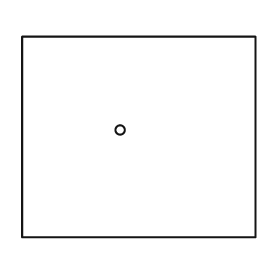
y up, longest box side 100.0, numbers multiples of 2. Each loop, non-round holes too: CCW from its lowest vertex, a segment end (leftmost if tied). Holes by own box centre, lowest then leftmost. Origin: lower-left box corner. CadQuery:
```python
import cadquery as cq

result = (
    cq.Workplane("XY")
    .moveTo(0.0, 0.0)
    .lineTo(100.0, 0.0)
    .lineTo(100.0, 86.0)
    .lineTo(0.0, 86.0)
    .close()
    .moveTo(42.0, 46.0)
    .circle(2.0)
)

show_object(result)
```